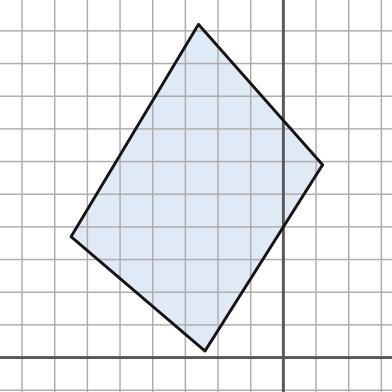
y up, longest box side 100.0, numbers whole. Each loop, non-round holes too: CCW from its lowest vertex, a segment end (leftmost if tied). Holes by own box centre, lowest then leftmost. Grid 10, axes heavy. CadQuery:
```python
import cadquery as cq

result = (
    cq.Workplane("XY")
    .moveTo(-24.0, 2.0)
    .lineTo(12.0, 59.0)
    .lineTo(-26.0, 102.0)
    .lineTo(-65.0, 37.0)
    .close()
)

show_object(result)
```